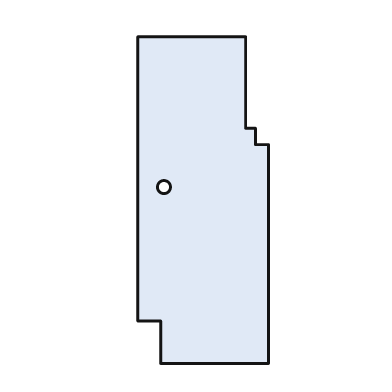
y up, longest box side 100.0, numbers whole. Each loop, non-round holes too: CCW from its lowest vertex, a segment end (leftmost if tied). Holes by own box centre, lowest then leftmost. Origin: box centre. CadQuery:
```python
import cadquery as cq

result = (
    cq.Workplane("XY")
    .moveTo(-13.0, -50.0)
    .lineTo(20.0, -50.0)
    .lineTo(20.0, 17.0)
    .lineTo(16.0, 17.0)
    .lineTo(16.0, 22.0)
    .lineTo(13.0, 22.0)
    .lineTo(13.0, 50.0)
    .lineTo(-20.0, 50.0)
    .lineTo(-20.0, -37.0)
    .lineTo(-13.0, -37.0)
    .close()
    .moveTo(-12.0, 4.0)
    .circle(2.0)
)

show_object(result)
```